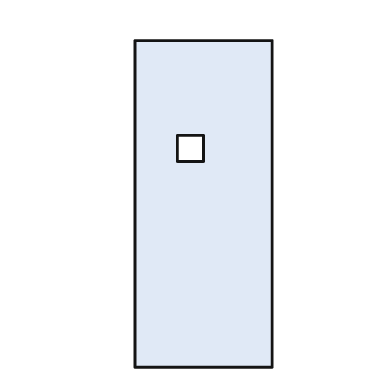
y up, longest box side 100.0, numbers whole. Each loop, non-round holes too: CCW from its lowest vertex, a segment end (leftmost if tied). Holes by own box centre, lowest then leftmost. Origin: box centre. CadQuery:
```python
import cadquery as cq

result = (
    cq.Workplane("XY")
    .moveTo(-21.0, -50.0)
    .lineTo(21.0, -50.0)
    .lineTo(21.0, 50.0)
    .lineTo(-21.0, 50.0)
    .close()
    .moveTo(-8.0, 13.0)
    .lineTo(0.0, 13.0)
    .lineTo(0.0, 21.0)
    .lineTo(-8.0, 21.0)
    .close()
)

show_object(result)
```